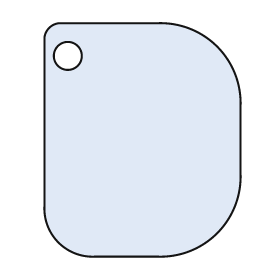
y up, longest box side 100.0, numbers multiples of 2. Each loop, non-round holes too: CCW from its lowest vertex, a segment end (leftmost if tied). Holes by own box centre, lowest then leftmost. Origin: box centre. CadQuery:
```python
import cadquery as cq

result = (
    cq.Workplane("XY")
    .moveTo(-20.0, -50.0)
    .lineTo(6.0, -50.0)
    .threePointArc((32.0, -40.0), (42.0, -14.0))
    .lineTo(42.0, 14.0)
    .threePointArc((32.0, 40.0), (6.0, 50.0))
    .lineTo(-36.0, 50.0)
    .threePointArc((-40.0, 48.0), (-42.0, 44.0))
    .lineTo(-42.0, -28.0)
    .threePointArc((-36.0, -44.0), (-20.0, -50.0))
    .close()
    .moveTo(-32.0, 36.0)
    .circle(6.0)
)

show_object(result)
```